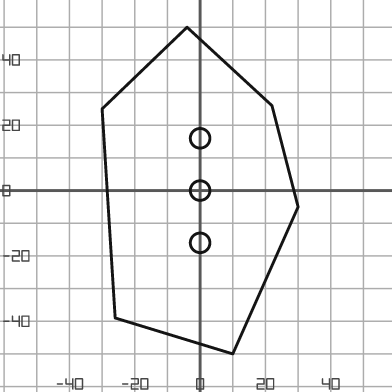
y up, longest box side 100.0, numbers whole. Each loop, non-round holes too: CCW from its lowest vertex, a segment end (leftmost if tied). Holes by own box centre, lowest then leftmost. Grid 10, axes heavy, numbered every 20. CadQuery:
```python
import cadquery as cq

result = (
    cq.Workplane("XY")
    .moveTo(10.0, -50.0)
    .lineTo(30.0, -5.0)
    .lineTo(22.0, 26.0)
    .lineTo(-4.0, 50.0)
    .lineTo(-30.0, 25.0)
    .lineTo(-26.0, -39.0)
    .close()
    .moveTo(0.0, -16.0)
    .circle(3.0)
    .moveTo(0.0, 0.0)
    .circle(3.0)
    .moveTo(0.0, 16.0)
    .circle(3.0)
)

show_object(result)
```